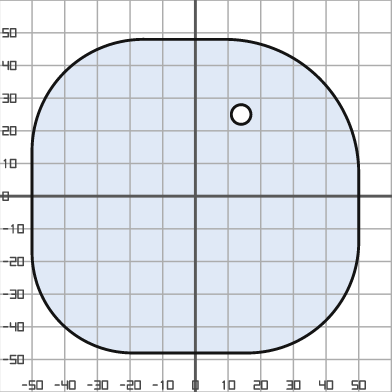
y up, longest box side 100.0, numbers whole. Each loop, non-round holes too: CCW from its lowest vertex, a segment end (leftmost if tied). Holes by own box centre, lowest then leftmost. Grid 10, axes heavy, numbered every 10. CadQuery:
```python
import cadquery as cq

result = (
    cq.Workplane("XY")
    .moveTo(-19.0, -48.0)
    .lineTo(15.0, -48.0)
    .threePointArc((40.0, -38.0), (50.0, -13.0))
    .lineTo(50.0, 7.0)
    .threePointArc((38.0, 36.0), (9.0, 48.0))
    .lineTo(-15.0, 48.0)
    .threePointArc((-40.0, 38.0), (-50.0, 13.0))
    .lineTo(-50.0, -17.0)
    .threePointArc((-41.0, -39.0), (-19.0, -48.0))
    .close()
    .moveTo(14.0, 25.0)
    .circle(3.0)
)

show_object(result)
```